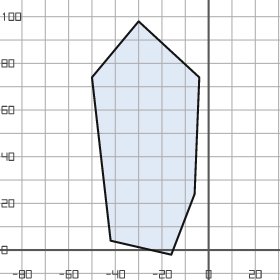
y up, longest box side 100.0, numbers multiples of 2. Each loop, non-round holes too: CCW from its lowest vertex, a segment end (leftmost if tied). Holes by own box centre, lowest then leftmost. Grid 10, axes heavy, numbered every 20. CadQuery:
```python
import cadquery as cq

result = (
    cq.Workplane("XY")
    .moveTo(-16.0, -2.0)
    .lineTo(-6.0, 24.0)
    .lineTo(-4.0, 74.0)
    .lineTo(-30.0, 98.0)
    .lineTo(-50.0, 74.0)
    .lineTo(-42.0, 4.0)
    .close()
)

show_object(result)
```